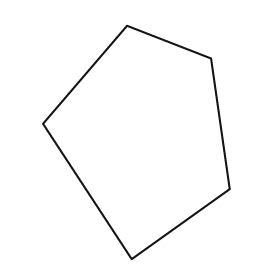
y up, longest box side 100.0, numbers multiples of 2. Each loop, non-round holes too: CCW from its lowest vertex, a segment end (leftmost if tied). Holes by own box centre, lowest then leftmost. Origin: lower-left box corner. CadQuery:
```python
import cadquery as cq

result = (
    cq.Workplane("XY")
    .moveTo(38.0, 0.0)
    .lineTo(80.0, 30.0)
    .lineTo(72.0, 86.0)
    .lineTo(36.0, 100.0)
    .lineTo(0.0, 58.0)
    .close()
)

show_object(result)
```